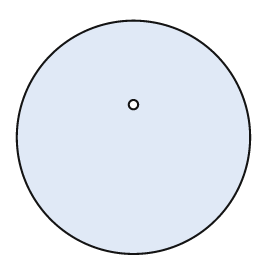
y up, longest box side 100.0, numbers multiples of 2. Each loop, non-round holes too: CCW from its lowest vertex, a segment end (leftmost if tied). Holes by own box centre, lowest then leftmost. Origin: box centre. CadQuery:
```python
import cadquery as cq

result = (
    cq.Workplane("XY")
    .moveTo(0.0, 0.0)
    .circle(50.0)
    .moveTo(0.0, 14.0)
    .circle(2.0)
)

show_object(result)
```